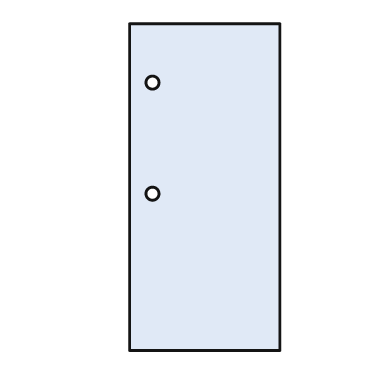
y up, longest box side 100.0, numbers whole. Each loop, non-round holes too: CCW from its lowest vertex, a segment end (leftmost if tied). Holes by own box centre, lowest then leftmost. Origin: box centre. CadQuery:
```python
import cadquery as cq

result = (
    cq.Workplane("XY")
    .moveTo(-23.0, -50.0)
    .lineTo(23.0, -50.0)
    .lineTo(23.0, 50.0)
    .lineTo(-23.0, 50.0)
    .close()
    .moveTo(-16.0, -2.0)
    .circle(2.0)
    .moveTo(-16.0, 32.0)
    .circle(2.0)
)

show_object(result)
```